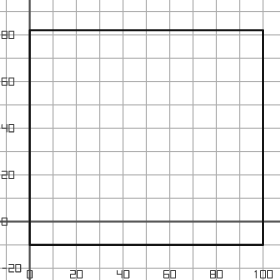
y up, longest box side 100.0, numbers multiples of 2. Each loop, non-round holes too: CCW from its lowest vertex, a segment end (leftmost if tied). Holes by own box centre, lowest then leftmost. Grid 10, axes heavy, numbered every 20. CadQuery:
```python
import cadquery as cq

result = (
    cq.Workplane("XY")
    .moveTo(0.0, -10.0)
    .lineTo(100.0, -10.0)
    .lineTo(100.0, 82.0)
    .lineTo(0.0, 82.0)
    .close()
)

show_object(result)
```